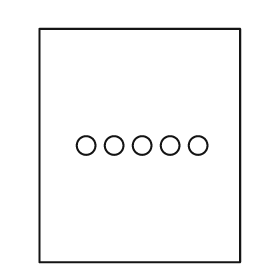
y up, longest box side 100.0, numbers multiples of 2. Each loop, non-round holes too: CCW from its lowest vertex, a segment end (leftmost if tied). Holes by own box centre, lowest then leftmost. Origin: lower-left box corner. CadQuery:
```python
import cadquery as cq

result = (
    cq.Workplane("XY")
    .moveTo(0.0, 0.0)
    .lineTo(86.0, 0.0)
    .lineTo(86.0, 100.0)
    .lineTo(0.0, 100.0)
    .close()
    .moveTo(20.0, 50.0)
    .circle(4.0)
    .moveTo(32.0, 50.0)
    .circle(4.0)
    .moveTo(44.0, 50.0)
    .circle(4.0)
    .moveTo(56.0, 50.0)
    .circle(4.0)
    .moveTo(68.0, 50.0)
    .circle(4.0)
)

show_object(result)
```